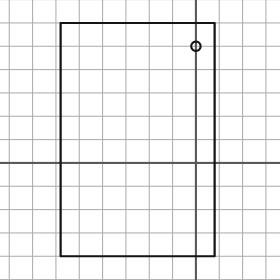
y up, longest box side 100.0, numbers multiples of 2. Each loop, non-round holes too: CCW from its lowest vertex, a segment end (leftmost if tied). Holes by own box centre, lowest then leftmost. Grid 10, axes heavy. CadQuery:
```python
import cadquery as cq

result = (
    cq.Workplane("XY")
    .moveTo(-58.0, -40.0)
    .lineTo(8.0, -40.0)
    .lineTo(8.0, 60.0)
    .lineTo(-58.0, 60.0)
    .close()
    .moveTo(0.0, 50.0)
    .circle(2.0)
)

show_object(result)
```